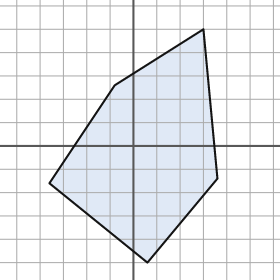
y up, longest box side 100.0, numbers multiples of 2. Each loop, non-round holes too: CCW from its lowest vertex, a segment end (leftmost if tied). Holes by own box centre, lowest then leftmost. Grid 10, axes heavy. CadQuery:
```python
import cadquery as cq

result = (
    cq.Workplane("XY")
    .moveTo(6.0, -50.0)
    .lineTo(36.0, -14.0)
    .lineTo(30.0, 50.0)
    .lineTo(-8.0, 26.0)
    .lineTo(-36.0, -16.0)
    .close()
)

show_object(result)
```